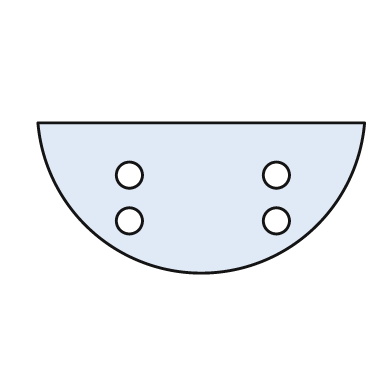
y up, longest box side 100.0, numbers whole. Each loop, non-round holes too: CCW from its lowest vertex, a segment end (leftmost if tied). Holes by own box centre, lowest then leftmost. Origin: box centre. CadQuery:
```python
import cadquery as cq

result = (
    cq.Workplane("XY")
    .moveTo(-50.0, 23.0)
    .threePointArc((0.0, -23.0), (50.0, 23.0))
    .close()
    .moveTo(-22.0, -7.0)
    .circle(4.0)
    .moveTo(23.0, -7.0)
    .circle(4.0)
    .moveTo(-22.0, 7.0)
    .circle(4.0)
    .moveTo(23.0, 7.0)
    .circle(4.0)
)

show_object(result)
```